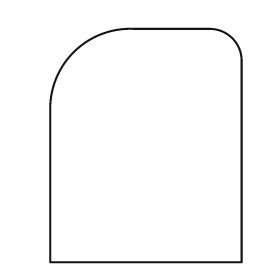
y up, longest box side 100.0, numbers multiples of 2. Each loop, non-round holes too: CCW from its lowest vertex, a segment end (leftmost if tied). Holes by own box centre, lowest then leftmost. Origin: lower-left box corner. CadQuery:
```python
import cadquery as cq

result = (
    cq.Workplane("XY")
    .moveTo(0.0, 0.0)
    .lineTo(82.0, 0.0)
    .lineTo(82.0, 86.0)
    .threePointArc((78.0, 96.0), (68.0, 100.0))
    .lineTo(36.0, 100.0)
    .threePointArc((10.0, 90.0), (0.0, 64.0))
    .close()
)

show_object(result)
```